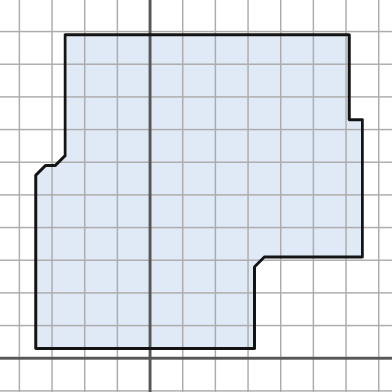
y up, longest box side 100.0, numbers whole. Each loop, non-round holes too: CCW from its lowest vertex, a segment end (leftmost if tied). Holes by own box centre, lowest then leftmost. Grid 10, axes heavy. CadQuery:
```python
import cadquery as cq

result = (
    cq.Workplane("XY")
    .moveTo(-35.0, 3.0)
    .lineTo(32.0, 3.0)
    .lineTo(32.0, 28.0)
    .lineTo(35.0, 31.0)
    .lineTo(65.0, 31.0)
    .lineTo(65.0, 73.0)
    .lineTo(61.0, 73.0)
    .lineTo(61.0, 99.0)
    .lineTo(-26.0, 99.0)
    .lineTo(-26.0, 62.0)
    .lineTo(-29.0, 59.0)
    .lineTo(-32.0, 59.0)
    .lineTo(-35.0, 56.0)
    .close()
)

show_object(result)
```